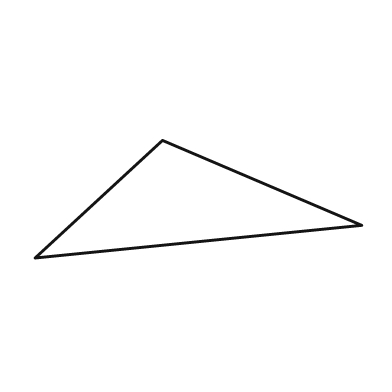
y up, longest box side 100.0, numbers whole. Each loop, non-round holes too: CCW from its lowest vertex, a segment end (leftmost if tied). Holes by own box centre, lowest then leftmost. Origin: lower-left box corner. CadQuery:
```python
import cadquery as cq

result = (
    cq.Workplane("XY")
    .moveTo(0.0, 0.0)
    .lineTo(100.0, 10.0)
    .lineTo(39.0, 36.0)
    .close()
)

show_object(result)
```